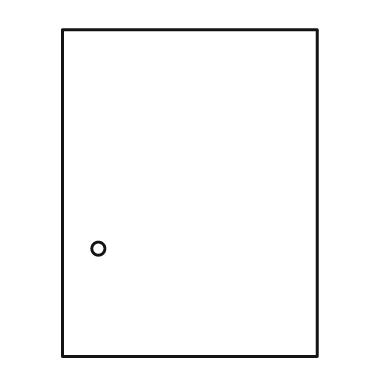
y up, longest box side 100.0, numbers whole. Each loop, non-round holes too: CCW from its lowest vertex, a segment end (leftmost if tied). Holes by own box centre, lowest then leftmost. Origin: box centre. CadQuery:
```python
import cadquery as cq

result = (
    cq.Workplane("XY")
    .moveTo(-39.0, -50.0)
    .lineTo(39.0, -50.0)
    .lineTo(39.0, 50.0)
    .lineTo(-39.0, 50.0)
    .close()
    .moveTo(-28.0, -17.0)
    .circle(2.0)
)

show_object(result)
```